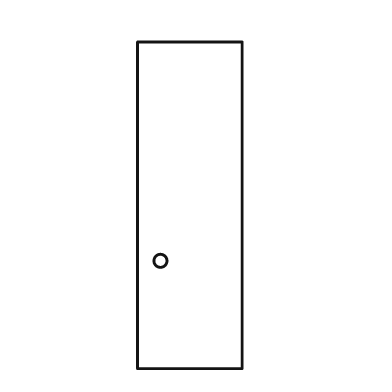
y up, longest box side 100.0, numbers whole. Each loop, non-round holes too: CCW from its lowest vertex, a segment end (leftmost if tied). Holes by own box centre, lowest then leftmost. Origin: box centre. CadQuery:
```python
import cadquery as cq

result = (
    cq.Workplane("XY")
    .moveTo(-16.0, -50.0)
    .lineTo(16.0, -50.0)
    .lineTo(16.0, 50.0)
    .lineTo(-16.0, 50.0)
    .close()
    .moveTo(-9.0, -17.0)
    .circle(2.0)
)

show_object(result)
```